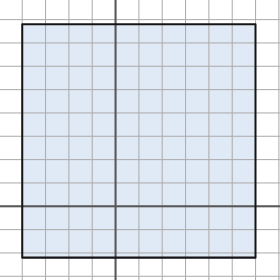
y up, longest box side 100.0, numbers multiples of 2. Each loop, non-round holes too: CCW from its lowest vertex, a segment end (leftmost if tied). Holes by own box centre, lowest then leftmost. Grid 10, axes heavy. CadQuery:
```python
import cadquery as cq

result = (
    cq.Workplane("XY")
    .moveTo(-40.0, -22.0)
    .lineTo(60.0, -22.0)
    .lineTo(60.0, 78.0)
    .lineTo(-40.0, 78.0)
    .close()
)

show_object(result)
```